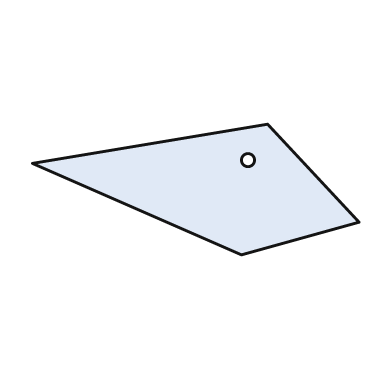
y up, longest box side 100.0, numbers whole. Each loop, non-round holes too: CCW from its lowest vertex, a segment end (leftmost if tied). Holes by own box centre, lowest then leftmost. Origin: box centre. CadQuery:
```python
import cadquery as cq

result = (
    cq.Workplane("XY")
    .moveTo(14.0, -20.0)
    .lineTo(50.0, -10.0)
    .lineTo(22.0, 20.0)
    .lineTo(-50.0, 8.0)
    .close()
    .moveTo(16.0, 9.0)
    .circle(2.0)
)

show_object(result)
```